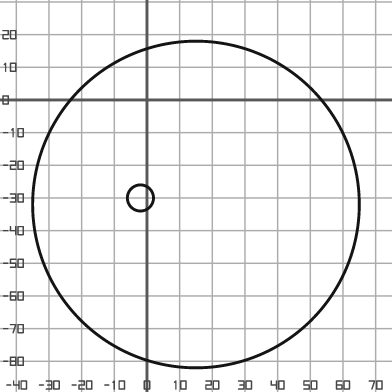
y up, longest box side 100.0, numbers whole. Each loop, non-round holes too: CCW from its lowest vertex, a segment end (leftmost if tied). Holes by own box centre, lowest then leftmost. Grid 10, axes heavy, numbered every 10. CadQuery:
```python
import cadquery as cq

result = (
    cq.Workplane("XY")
    .moveTo(15.0, -32.0)
    .circle(50.0)
    .moveTo(-2.0, -30.0)
    .circle(4.0)
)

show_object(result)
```